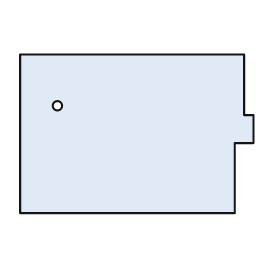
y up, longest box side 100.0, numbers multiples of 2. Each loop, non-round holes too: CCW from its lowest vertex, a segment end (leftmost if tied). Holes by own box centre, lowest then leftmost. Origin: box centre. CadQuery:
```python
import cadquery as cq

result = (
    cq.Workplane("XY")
    .moveTo(-50.0, -34.0)
    .lineTo(42.0, -34.0)
    .lineTo(42.0, -4.0)
    .lineTo(50.0, -4.0)
    .lineTo(50.0, 8.0)
    .lineTo(46.0, 8.0)
    .lineTo(46.0, 34.0)
    .lineTo(-50.0, 34.0)
    .close()
    .moveTo(-34.0, 12.0)
    .circle(2.0)
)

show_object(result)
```